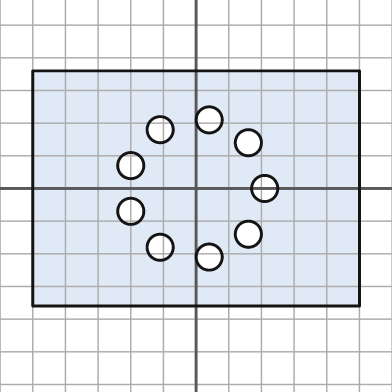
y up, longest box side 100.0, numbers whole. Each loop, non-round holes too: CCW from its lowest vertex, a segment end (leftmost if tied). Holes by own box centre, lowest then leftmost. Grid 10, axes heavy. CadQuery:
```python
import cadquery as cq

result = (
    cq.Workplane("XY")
    .moveTo(-50.0, -36.0)
    .lineTo(50.0, -36.0)
    .lineTo(50.0, 36.0)
    .lineTo(-50.0, 36.0)
    .close()
    .moveTo(4.0, -21.0)
    .circle(4.0)
    .moveTo(-11.0, -18.0)
    .circle(4.0)
    .moveTo(16.0, -14.0)
    .circle(4.0)
    .moveTo(-20.0, -7.0)
    .circle(4.0)
    .moveTo(21.0, 0.0)
    .circle(4.0)
    .moveTo(-20.0, 7.0)
    .circle(4.0)
    .moveTo(16.0, 14.0)
    .circle(4.0)
    .moveTo(-11.0, 18.0)
    .circle(4.0)
    .moveTo(4.0, 21.0)
    .circle(4.0)
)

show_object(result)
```